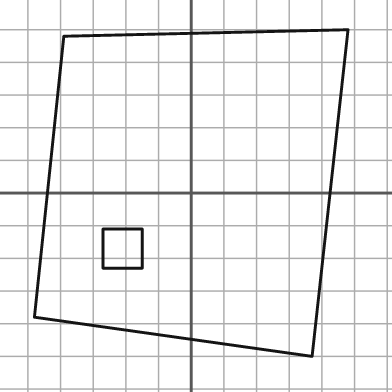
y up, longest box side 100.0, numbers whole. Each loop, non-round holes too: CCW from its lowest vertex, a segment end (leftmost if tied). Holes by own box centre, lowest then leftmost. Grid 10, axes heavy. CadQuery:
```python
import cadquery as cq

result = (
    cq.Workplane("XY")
    .moveTo(37.0, -50.0)
    .lineTo(48.0, 50.0)
    .lineTo(-39.0, 48.0)
    .lineTo(-48.0, -38.0)
    .close()
    .moveTo(-27.0, -23.0)
    .lineTo(-15.0, -23.0)
    .lineTo(-15.0, -11.0)
    .lineTo(-27.0, -11.0)
    .close()
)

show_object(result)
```